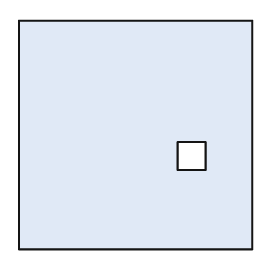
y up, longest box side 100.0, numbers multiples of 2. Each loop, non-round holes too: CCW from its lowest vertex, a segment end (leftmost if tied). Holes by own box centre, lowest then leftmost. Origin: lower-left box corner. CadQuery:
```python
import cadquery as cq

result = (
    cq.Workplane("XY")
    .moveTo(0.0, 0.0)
    .lineTo(100.0, 0.0)
    .lineTo(100.0, 98.0)
    .lineTo(0.0, 98.0)
    .close()
    .moveTo(68.0, 34.0)
    .lineTo(80.0, 34.0)
    .lineTo(80.0, 46.0)
    .lineTo(68.0, 46.0)
    .close()
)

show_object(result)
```